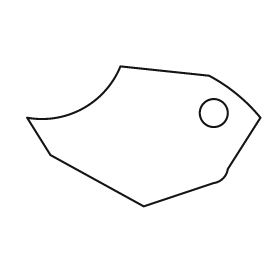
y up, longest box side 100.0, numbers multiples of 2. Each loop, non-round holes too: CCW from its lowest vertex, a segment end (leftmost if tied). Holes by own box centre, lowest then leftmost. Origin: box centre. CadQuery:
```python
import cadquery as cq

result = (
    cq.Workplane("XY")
    .moveTo(0.0, -30.0)
    .lineTo(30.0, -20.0)
    .threePointArc((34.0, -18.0), (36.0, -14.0))
    .lineTo(50.0, 8.0)
    .threePointArc((40.0, 18.0), (28.0, 26.0))
    .lineTo(-10.0, 30.0)
    .threePointArc((-26.0, 12.0), (-50.0, 8.0))
    .lineTo(-40.0, -8.0)
    .close()
    .moveTo(30.0, 10.0)
    .circle(6.0)
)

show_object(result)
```